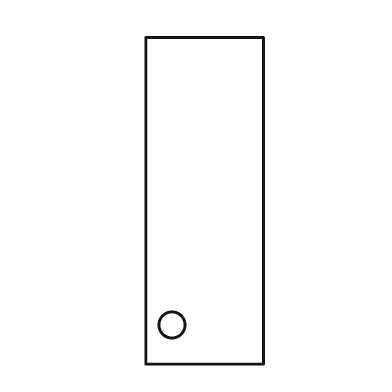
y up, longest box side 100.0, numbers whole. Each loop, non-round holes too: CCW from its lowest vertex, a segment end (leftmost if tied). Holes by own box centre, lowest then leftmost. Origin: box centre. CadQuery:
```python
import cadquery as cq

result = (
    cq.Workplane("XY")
    .moveTo(-18.0, -50.0)
    .lineTo(18.0, -50.0)
    .lineTo(18.0, 50.0)
    .lineTo(-18.0, 50.0)
    .close()
    .moveTo(-10.0, -38.0)
    .circle(4.0)
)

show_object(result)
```